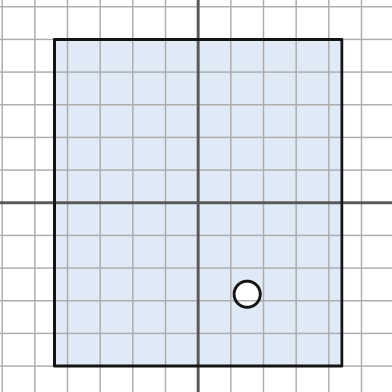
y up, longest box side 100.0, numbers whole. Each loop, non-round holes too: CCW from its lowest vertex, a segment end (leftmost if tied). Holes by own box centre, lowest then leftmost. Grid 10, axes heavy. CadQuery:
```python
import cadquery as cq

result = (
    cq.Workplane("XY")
    .moveTo(-44.0, -50.0)
    .lineTo(44.0, -50.0)
    .lineTo(44.0, 50.0)
    .lineTo(-44.0, 50.0)
    .close()
    .moveTo(15.0, -28.0)
    .circle(4.0)
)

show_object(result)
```